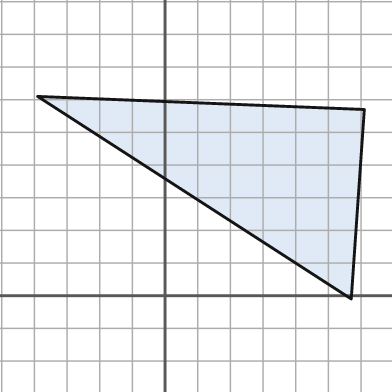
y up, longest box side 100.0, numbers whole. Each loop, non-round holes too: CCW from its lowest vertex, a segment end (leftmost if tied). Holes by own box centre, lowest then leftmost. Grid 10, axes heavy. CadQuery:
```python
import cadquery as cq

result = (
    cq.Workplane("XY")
    .moveTo(57.0, -1.0)
    .lineTo(61.0, 57.0)
    .lineTo(-39.0, 61.0)
    .close()
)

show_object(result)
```